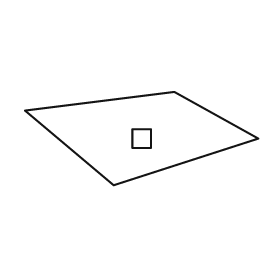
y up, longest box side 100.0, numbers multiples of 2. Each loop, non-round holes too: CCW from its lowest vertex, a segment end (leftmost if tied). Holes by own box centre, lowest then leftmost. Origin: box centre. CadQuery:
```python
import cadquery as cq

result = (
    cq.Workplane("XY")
    .moveTo(-12.0, -20.0)
    .lineTo(50.0, 0.0)
    .lineTo(14.0, 20.0)
    .lineTo(-50.0, 12.0)
    .close()
    .moveTo(-4.0, -4.0)
    .lineTo(4.0, -4.0)
    .lineTo(4.0, 4.0)
    .lineTo(-4.0, 4.0)
    .close()
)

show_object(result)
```